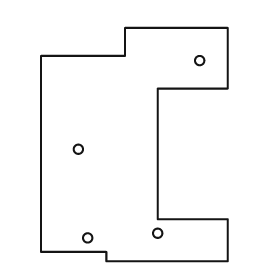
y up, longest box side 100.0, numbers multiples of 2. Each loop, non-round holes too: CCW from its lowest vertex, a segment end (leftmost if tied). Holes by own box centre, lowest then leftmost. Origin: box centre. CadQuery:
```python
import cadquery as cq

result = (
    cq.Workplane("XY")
    .moveTo(-12.0, -50.0)
    .lineTo(40.0, -50.0)
    .lineTo(40.0, -32.0)
    .lineTo(10.0, -32.0)
    .lineTo(10.0, 24.0)
    .lineTo(40.0, 24.0)
    .lineTo(40.0, 50.0)
    .lineTo(-4.0, 50.0)
    .lineTo(-4.0, 38.0)
    .lineTo(-40.0, 38.0)
    .lineTo(-40.0, -46.0)
    .lineTo(-12.0, -46.0)
    .close()
    .moveTo(-20.0, -40.0)
    .circle(2.0)
    .moveTo(10.0, -38.0)
    .circle(2.0)
    .moveTo(-24.0, -2.0)
    .circle(2.0)
    .moveTo(28.0, 36.0)
    .circle(2.0)
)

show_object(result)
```